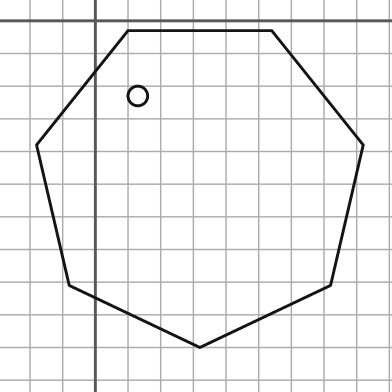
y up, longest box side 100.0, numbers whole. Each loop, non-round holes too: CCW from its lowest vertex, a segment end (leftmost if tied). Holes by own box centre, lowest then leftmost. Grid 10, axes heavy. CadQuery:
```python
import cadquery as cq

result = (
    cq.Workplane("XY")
    .moveTo(32.0, -100.0)
    .lineTo(72.0, -81.0)
    .lineTo(82.0, -38.0)
    .lineTo(54.0, -3.0)
    .lineTo(10.0, -3.0)
    .lineTo(-18.0, -38.0)
    .lineTo(-8.0, -81.0)
    .close()
    .moveTo(13.0, -23.0)
    .circle(3.0)
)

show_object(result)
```